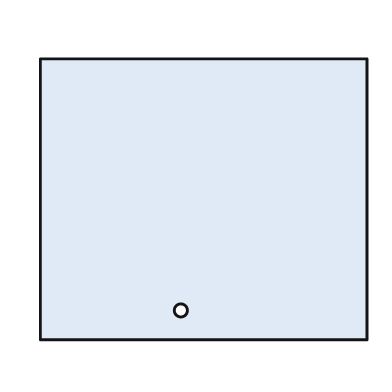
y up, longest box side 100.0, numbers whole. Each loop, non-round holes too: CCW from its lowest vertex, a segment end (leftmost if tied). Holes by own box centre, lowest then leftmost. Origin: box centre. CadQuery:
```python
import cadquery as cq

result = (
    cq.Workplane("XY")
    .moveTo(-50.0, -43.0)
    .lineTo(50.0, -43.0)
    .lineTo(50.0, 43.0)
    .lineTo(-50.0, 43.0)
    .close()
    .moveTo(-7.0, -34.0)
    .circle(2.0)
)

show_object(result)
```